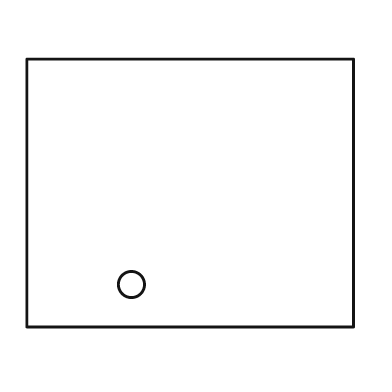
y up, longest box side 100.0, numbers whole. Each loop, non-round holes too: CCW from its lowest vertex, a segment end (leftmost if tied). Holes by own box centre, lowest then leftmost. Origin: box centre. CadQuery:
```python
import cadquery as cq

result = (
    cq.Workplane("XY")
    .moveTo(-50.0, -41.0)
    .lineTo(50.0, -41.0)
    .lineTo(50.0, 41.0)
    .lineTo(-50.0, 41.0)
    .close()
    .moveTo(-18.0, -28.0)
    .circle(4.0)
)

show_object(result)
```